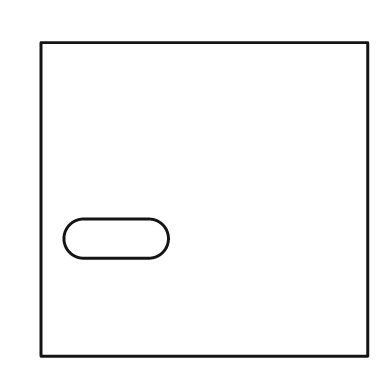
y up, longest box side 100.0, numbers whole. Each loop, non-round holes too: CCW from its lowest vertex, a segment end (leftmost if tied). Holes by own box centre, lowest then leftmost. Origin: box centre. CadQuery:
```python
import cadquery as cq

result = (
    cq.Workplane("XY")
    .moveTo(-50.0, -48.0)
    .lineTo(50.0, -48.0)
    .lineTo(50.0, 48.0)
    .lineTo(-50.0, 48.0)
    .close()
    .moveTo(-37.0, -18.0)
    .lineTo(-17.0, -18.0)
    .threePointArc((-11.0, -12.0), (-17.0, -6.0))
    .lineTo(-37.0, -6.0)
    .threePointArc((-43.0, -12.0), (-37.0, -18.0))
    .close()
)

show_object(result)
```